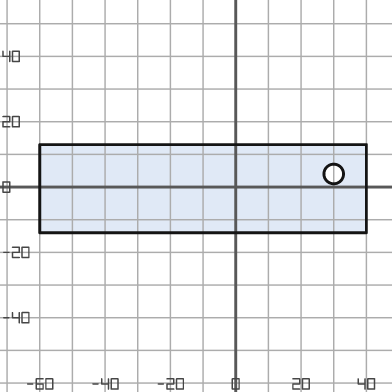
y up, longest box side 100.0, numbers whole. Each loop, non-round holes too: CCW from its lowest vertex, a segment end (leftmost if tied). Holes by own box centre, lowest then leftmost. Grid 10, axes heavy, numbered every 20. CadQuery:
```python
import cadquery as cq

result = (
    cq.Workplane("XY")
    .moveTo(-60.0, -14.0)
    .lineTo(40.0, -14.0)
    .lineTo(40.0, 13.0)
    .lineTo(-60.0, 13.0)
    .close()
    .moveTo(30.0, 4.0)
    .circle(3.0)
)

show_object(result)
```